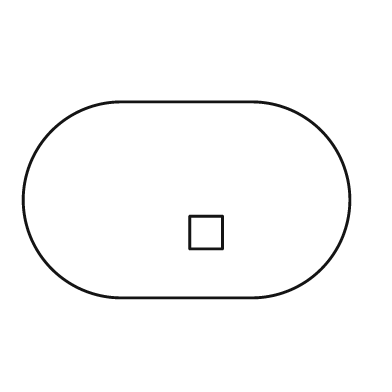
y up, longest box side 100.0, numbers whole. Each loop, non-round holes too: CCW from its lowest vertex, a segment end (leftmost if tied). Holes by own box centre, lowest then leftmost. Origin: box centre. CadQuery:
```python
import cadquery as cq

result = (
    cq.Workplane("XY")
    .moveTo(-20.0, -30.0)
    .lineTo(20.0, -30.0)
    .threePointArc((50.0, 0.0), (20.0, 30.0))
    .lineTo(-20.0, 30.0)
    .threePointArc((-50.0, 0.0), (-20.0, -30.0))
    .close()
    .moveTo(1.0, -15.0)
    .lineTo(11.0, -15.0)
    .lineTo(11.0, -5.0)
    .lineTo(1.0, -5.0)
    .close()
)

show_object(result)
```